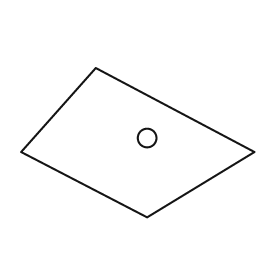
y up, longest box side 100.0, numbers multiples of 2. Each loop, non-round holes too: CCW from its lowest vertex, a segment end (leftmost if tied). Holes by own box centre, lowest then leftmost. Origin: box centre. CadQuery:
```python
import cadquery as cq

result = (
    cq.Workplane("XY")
    .moveTo(4.0, -32.0)
    .lineTo(50.0, -4.0)
    .lineTo(-18.0, 32.0)
    .lineTo(-50.0, -4.0)
    .close()
    .moveTo(4.0, 2.0)
    .circle(4.0)
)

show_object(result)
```